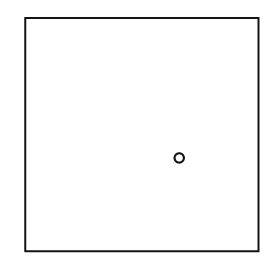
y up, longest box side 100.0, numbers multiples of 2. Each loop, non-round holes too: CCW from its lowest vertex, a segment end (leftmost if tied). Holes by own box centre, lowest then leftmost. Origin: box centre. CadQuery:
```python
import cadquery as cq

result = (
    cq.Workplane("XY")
    .moveTo(-50.0, -50.0)
    .lineTo(50.0, -50.0)
    .lineTo(50.0, 50.0)
    .lineTo(-50.0, 50.0)
    .close()
    .moveTo(16.0, -10.0)
    .circle(2.0)
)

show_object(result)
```